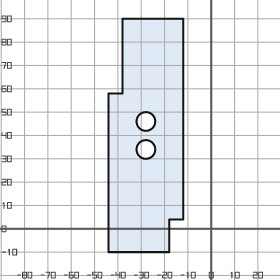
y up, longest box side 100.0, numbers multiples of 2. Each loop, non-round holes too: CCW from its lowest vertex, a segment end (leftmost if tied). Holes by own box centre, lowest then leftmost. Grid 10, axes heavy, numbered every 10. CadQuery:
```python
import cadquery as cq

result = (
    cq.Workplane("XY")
    .moveTo(-44.0, -10.0)
    .lineTo(-18.0, -10.0)
    .lineTo(-18.0, 4.0)
    .lineTo(-12.0, 4.0)
    .lineTo(-12.0, 90.0)
    .lineTo(-38.0, 90.0)
    .lineTo(-38.0, 58.0)
    .lineTo(-44.0, 58.0)
    .close()
    .moveTo(-28.0, 34.0)
    .circle(4.0)
    .moveTo(-28.0, 46.0)
    .circle(4.0)
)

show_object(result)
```